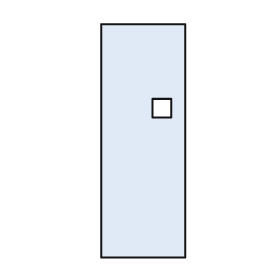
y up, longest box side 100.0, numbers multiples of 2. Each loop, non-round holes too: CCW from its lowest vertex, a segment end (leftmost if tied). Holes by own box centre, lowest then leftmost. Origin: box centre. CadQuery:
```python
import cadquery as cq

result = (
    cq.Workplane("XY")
    .moveTo(-18.0, -50.0)
    .lineTo(18.0, -50.0)
    .lineTo(18.0, 50.0)
    .lineTo(-18.0, 50.0)
    .close()
    .moveTo(4.0, 10.0)
    .lineTo(12.0, 10.0)
    .lineTo(12.0, 18.0)
    .lineTo(4.0, 18.0)
    .close()
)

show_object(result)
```